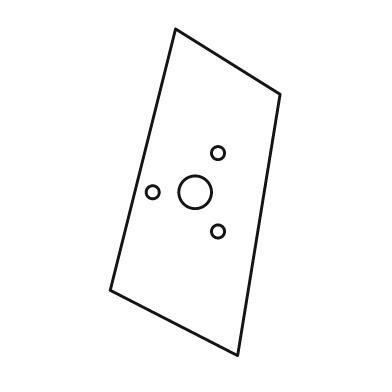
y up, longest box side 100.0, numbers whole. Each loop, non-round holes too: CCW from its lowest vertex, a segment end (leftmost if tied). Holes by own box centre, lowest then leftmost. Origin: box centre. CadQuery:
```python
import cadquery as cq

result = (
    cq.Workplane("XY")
    .moveTo(13.0, -50.0)
    .lineTo(26.0, 30.0)
    .lineTo(-6.0, 50.0)
    .lineTo(-26.0, -30.0)
    .close()
    .moveTo(7.0, -12.0)
    .circle(2.0)
    .moveTo(-13.0, 0.0)
    .circle(2.0)
    .moveTo(0.0, 0.0)
    .circle(5.0)
    .moveTo(7.0, 12.0)
    .circle(2.0)
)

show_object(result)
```